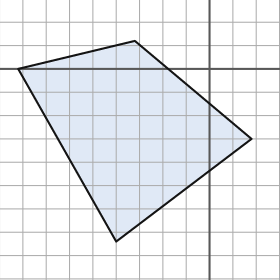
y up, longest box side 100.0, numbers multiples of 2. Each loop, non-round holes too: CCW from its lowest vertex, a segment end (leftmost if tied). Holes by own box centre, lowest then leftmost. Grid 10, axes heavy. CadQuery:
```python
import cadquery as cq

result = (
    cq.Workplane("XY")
    .moveTo(-40.0, -74.0)
    .lineTo(18.0, -30.0)
    .lineTo(-32.0, 12.0)
    .lineTo(-82.0, 0.0)
    .close()
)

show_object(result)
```